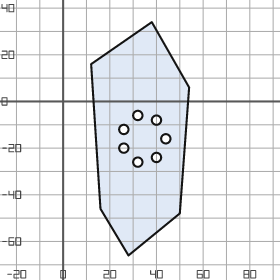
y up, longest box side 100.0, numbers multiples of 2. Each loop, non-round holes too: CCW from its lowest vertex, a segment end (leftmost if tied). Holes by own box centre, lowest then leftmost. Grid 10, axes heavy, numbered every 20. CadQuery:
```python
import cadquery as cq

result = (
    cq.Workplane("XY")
    .moveTo(28.0, -66.0)
    .lineTo(50.0, -48.0)
    .lineTo(54.0, 6.0)
    .lineTo(38.0, 34.0)
    .lineTo(12.0, 16.0)
    .lineTo(16.0, -46.0)
    .close()
    .moveTo(32.0, -26.0)
    .circle(2.0)
    .moveTo(40.0, -24.0)
    .circle(2.0)
    .moveTo(26.0, -20.0)
    .circle(2.0)
    .moveTo(44.0, -16.0)
    .circle(2.0)
    .moveTo(26.0, -12.0)
    .circle(2.0)
    .moveTo(40.0, -8.0)
    .circle(2.0)
    .moveTo(32.0, -6.0)
    .circle(2.0)
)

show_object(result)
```